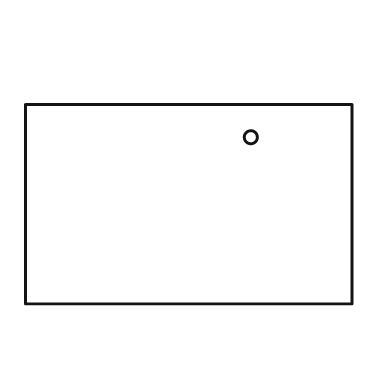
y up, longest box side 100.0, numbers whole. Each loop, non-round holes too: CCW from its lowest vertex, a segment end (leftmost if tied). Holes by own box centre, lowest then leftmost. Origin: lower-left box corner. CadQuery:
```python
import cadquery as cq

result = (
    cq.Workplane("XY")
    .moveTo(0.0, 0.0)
    .lineTo(100.0, 0.0)
    .lineTo(100.0, 61.0)
    .lineTo(0.0, 61.0)
    .close()
    .moveTo(69.0, 51.0)
    .circle(2.0)
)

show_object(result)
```